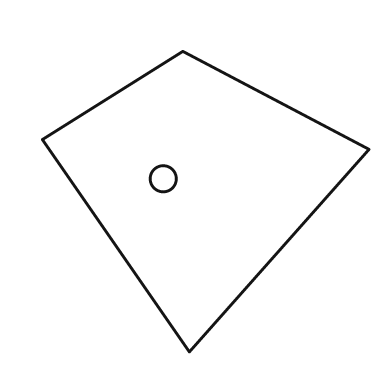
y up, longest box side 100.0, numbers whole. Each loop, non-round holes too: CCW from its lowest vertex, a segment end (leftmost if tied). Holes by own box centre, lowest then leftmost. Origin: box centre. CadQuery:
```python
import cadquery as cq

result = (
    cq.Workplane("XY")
    .moveTo(-5.0, -46.0)
    .lineTo(50.0, 16.0)
    .lineTo(-7.0, 46.0)
    .lineTo(-50.0, 19.0)
    .close()
    .moveTo(-13.0, 7.0)
    .circle(4.0)
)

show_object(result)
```